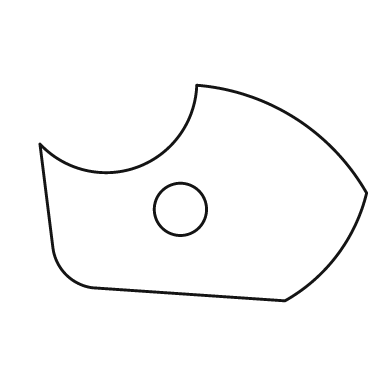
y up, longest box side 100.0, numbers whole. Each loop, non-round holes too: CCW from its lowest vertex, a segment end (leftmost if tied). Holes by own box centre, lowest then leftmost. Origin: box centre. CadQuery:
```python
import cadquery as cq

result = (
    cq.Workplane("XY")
    .moveTo(25.0, -33.0)
    .threePointArc((41.0, -19.0), (50.0, 0.0))
    .threePointArc((28.0, 23.0), (-2.0, 33.0))
    .threePointArc((-20.0, 8.0), (-50.0, 15.0))
    .lineTo(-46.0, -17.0)
    .threePointArc((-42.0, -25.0), (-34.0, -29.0))
    .close()
    .moveTo(-7.0, -5.0)
    .circle(8.0)
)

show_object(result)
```